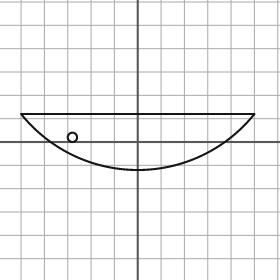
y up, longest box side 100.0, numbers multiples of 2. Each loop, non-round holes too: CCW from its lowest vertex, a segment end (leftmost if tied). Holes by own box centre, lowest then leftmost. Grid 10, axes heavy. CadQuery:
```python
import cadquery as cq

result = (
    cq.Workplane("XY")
    .moveTo(-50.0, 12.0)
    .threePointArc((0.0, -12.0), (50.0, 12.0))
    .close()
    .moveTo(-28.0, 2.0)
    .circle(2.0)
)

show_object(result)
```